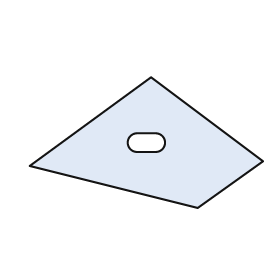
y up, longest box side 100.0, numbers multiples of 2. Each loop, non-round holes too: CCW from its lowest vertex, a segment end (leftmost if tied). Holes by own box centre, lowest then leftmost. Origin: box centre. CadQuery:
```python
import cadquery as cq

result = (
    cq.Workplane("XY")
    .moveTo(22.0, -28.0)
    .lineTo(50.0, -8.0)
    .lineTo(2.0, 28.0)
    .lineTo(-50.0, -10.0)
    .close()
    .moveTo(-4.0, -4.0)
    .lineTo(4.0, -4.0)
    .threePointArc((8.0, 0.0), (4.0, 4.0))
    .lineTo(-4.0, 4.0)
    .threePointArc((-8.0, 0.0), (-4.0, -4.0))
    .close()
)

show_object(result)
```